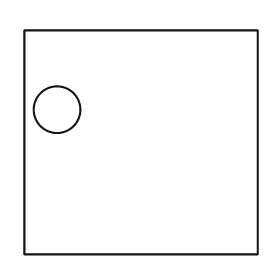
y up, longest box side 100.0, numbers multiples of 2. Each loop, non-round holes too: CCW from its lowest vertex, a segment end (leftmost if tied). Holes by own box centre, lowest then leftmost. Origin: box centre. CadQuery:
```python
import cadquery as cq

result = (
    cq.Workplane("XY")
    .moveTo(-50.0, -48.0)
    .lineTo(50.0, -48.0)
    .lineTo(50.0, 48.0)
    .lineTo(-50.0, 48.0)
    .close()
    .moveTo(-36.0, 14.0)
    .circle(10.0)
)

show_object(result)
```